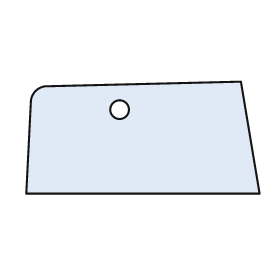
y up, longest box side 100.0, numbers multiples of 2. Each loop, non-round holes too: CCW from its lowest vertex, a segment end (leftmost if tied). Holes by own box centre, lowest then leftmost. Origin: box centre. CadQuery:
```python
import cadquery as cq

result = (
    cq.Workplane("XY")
    .moveTo(-50.0, -24.0)
    .lineTo(50.0, -24.0)
    .lineTo(42.0, 24.0)
    .lineTo(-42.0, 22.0)
    .threePointArc((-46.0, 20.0), (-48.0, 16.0))
    .close()
    .moveTo(-10.0, 12.0)
    .circle(4.0)
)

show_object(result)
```